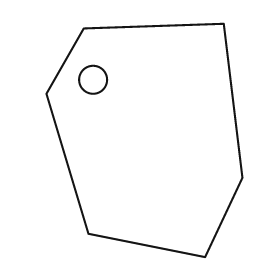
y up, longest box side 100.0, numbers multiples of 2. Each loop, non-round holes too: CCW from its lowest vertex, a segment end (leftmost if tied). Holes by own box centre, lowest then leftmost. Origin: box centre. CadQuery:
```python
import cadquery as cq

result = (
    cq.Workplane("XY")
    .moveTo(26.0, -50.0)
    .lineTo(42.0, -16.0)
    .lineTo(34.0, 50.0)
    .lineTo(-26.0, 48.0)
    .lineTo(-42.0, 20.0)
    .lineTo(-24.0, -40.0)
    .close()
    .moveTo(-22.0, 26.0)
    .circle(6.0)
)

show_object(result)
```